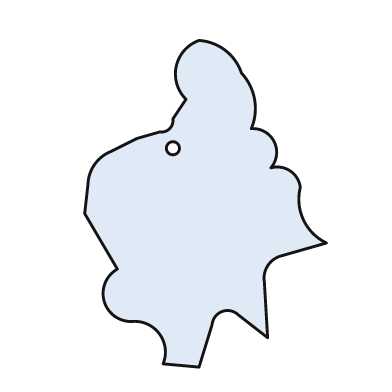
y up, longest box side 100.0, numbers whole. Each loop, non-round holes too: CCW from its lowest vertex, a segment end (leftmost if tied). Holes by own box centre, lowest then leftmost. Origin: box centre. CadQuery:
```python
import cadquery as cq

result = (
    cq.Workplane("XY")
    .moveTo(-2.0, -50.0)
    .lineTo(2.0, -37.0)
    .threePointArc((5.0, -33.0), (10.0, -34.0))
    .lineTo(19.0, -41.0)
    .lineTo(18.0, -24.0)
    .threePointArc((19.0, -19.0), (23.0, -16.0))
    .lineTo(37.0, -12.0)
    .threePointArc((30.0, -5.0), (29.0, 5.0))
    .threePointArc((26.0, 10.0), (20.0, 11.0))
    .threePointArc((21.0, 19.0), (14.0, 23.0))
    .threePointArc((15.0, 32.0), (11.0, 40.0))
    .threePointArc((6.0, 47.0), (-2.0, 50.0))
    .threePointArc((-9.0, 42.0), (-6.0, 32.0))
    .lineTo(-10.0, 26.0)
    .threePointArc((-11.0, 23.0), (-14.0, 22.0))
    .lineTo(-21.0, 20.0)
    .lineTo(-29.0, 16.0)
    .threePointArc((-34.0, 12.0), (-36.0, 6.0))
    .lineTo(-37.0, -3.0)
    .lineTo(-27.0, -20.0)
    .threePointArc((-31.0, -30.0), (-22.0, -36.0))
    .threePointArc((-14.0, -40.0), (-13.0, -49.0))
    .close()
    .moveTo(-10.0, 17.0)
    .circle(2.0)
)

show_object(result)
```